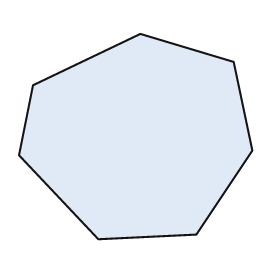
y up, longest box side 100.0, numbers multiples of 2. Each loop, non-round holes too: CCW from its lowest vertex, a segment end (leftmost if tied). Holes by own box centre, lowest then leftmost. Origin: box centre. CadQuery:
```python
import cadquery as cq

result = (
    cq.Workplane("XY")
    .moveTo(-16.0, -44.0)
    .lineTo(26.0, -42.0)
    .lineTo(50.0, -6.0)
    .lineTo(42.0, 32.0)
    .lineTo(2.0, 44.0)
    .lineTo(-44.0, 22.0)
    .lineTo(-50.0, -8.0)
    .close()
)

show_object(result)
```